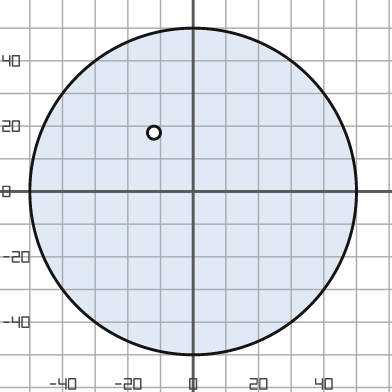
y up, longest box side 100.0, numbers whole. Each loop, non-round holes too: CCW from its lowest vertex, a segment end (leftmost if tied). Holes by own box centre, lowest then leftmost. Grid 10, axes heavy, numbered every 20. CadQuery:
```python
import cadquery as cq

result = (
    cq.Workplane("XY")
    .moveTo(0.0, 0.0)
    .circle(50.0)
    .moveTo(-12.0, 18.0)
    .circle(2.0)
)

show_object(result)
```